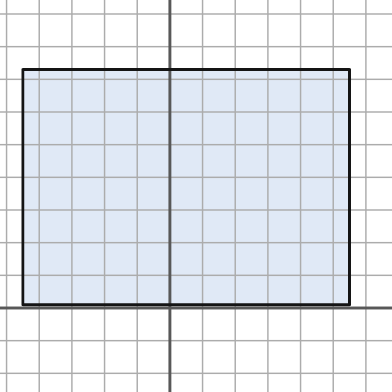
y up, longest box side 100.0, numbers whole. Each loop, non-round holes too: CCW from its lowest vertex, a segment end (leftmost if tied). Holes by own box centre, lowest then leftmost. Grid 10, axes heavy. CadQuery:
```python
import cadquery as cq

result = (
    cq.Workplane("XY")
    .moveTo(-45.0, 1.0)
    .lineTo(55.0, 1.0)
    .lineTo(55.0, 73.0)
    .lineTo(-45.0, 73.0)
    .close()
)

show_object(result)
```